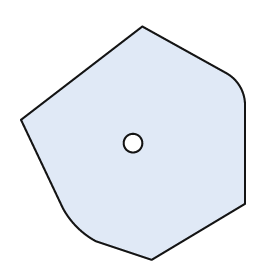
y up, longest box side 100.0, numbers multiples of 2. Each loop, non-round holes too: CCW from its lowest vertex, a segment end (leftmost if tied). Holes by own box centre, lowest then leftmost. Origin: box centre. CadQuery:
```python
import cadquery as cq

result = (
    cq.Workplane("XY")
    .moveTo(8.0, -50.0)
    .lineTo(48.0, -26.0)
    .lineTo(48.0, 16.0)
    .threePointArc((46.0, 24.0), (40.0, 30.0))
    .lineTo(4.0, 50.0)
    .lineTo(-48.0, 10.0)
    .lineTo(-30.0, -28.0)
    .threePointArc((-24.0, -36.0), (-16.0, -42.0))
    .close()
    .moveTo(0.0, 0.0)
    .circle(4.0)
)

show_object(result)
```